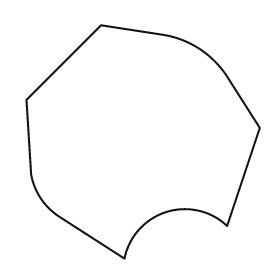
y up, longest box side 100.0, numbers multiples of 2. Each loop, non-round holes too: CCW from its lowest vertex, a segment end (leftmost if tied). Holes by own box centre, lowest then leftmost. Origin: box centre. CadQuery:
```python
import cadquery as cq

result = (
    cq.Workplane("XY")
    .moveTo(-8.0, -50.0)
    .threePointArc((10.0, -30.0), (36.0, -36.0))
    .lineTo(50.0, 6.0)
    .lineTo(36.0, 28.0)
    .threePointArc((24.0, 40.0), (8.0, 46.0))
    .lineTo(-18.0, 50.0)
    .lineTo(-50.0, 18.0)
    .lineTo(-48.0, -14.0)
    .threePointArc((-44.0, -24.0), (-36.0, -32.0))
    .close()
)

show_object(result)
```